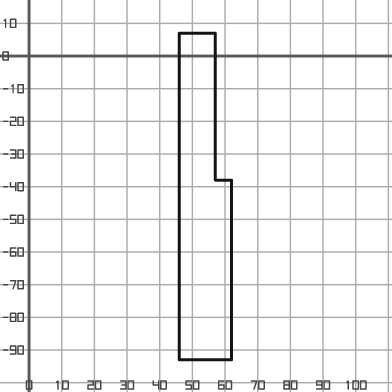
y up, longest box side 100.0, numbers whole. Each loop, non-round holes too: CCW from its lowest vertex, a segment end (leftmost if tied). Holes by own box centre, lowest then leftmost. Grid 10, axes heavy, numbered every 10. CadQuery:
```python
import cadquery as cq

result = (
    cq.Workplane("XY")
    .moveTo(46.0, -93.0)
    .lineTo(62.0, -93.0)
    .lineTo(62.0, -38.0)
    .lineTo(57.0, -38.0)
    .lineTo(57.0, 7.0)
    .lineTo(46.0, 7.0)
    .close()
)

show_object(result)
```